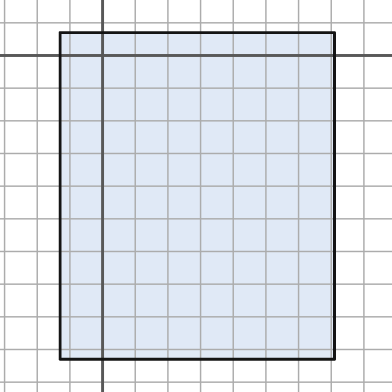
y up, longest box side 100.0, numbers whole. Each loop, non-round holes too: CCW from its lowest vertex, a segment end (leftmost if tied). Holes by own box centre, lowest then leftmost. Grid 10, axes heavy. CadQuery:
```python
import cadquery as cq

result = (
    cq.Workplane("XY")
    .moveTo(-13.0, -93.0)
    .lineTo(71.0, -93.0)
    .lineTo(71.0, 7.0)
    .lineTo(-13.0, 7.0)
    .close()
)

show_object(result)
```